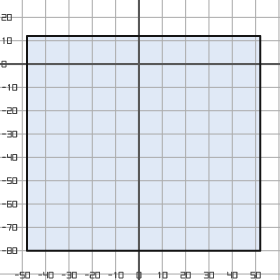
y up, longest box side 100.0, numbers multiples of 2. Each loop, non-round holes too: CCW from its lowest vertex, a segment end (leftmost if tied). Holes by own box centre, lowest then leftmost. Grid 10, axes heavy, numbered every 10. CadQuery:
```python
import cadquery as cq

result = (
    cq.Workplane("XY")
    .moveTo(-48.0, -80.0)
    .lineTo(52.0, -80.0)
    .lineTo(52.0, 12.0)
    .lineTo(-48.0, 12.0)
    .close()
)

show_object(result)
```